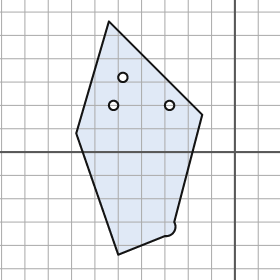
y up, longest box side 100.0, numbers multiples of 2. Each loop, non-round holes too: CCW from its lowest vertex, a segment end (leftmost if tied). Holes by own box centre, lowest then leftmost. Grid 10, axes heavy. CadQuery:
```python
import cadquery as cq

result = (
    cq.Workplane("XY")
    .moveTo(-50.0, -44.0)
    .lineTo(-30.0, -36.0)
    .threePointArc((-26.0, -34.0), (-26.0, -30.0))
    .lineTo(-14.0, 16.0)
    .lineTo(-54.0, 56.0)
    .lineTo(-68.0, 8.0)
    .close()
    .moveTo(-52.0, 20.0)
    .circle(2.0)
    .moveTo(-28.0, 20.0)
    .circle(2.0)
    .moveTo(-48.0, 32.0)
    .circle(2.0)
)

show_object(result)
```